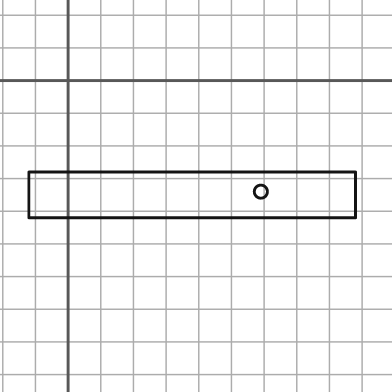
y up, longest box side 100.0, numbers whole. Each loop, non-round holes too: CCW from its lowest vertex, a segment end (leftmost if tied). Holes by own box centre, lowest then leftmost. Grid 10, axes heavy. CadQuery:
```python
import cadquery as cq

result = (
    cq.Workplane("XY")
    .moveTo(-12.0, -42.0)
    .lineTo(88.0, -42.0)
    .lineTo(88.0, -28.0)
    .lineTo(-12.0, -28.0)
    .close()
    .moveTo(59.0, -34.0)
    .circle(2.0)
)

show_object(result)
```